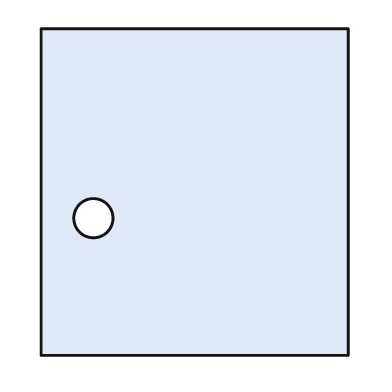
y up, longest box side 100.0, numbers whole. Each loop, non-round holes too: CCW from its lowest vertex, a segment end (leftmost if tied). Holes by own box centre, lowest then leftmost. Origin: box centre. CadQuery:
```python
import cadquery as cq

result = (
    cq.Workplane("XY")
    .moveTo(-47.0, -50.0)
    .lineTo(47.0, -50.0)
    .lineTo(47.0, 50.0)
    .lineTo(-47.0, 50.0)
    .close()
    .moveTo(-31.0, -8.0)
    .circle(6.0)
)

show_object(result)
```